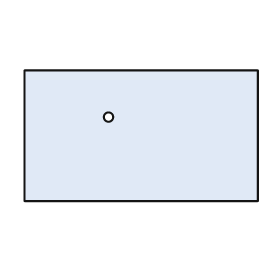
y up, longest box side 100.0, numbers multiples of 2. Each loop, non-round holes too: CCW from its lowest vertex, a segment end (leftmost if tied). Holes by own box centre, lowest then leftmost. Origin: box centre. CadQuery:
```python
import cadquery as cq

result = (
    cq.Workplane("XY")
    .moveTo(-50.0, -28.0)
    .lineTo(50.0, -28.0)
    .lineTo(50.0, 28.0)
    .lineTo(-50.0, 28.0)
    .close()
    .moveTo(-14.0, 8.0)
    .circle(2.0)
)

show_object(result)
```